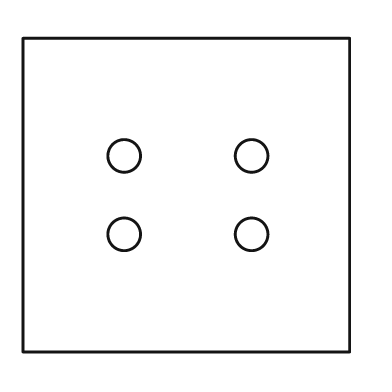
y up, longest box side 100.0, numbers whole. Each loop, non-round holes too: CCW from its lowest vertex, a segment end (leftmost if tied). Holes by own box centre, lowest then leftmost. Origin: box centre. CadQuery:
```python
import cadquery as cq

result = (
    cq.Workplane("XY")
    .moveTo(-50.0, -48.0)
    .lineTo(50.0, -48.0)
    .lineTo(50.0, 48.0)
    .lineTo(-50.0, 48.0)
    .close()
    .moveTo(-19.0, -12.0)
    .circle(5.0)
    .moveTo(20.0, -12.0)
    .circle(5.0)
    .moveTo(-19.0, 12.0)
    .circle(5.0)
    .moveTo(20.0, 12.0)
    .circle(5.0)
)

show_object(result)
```